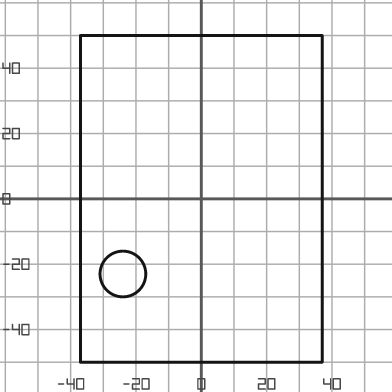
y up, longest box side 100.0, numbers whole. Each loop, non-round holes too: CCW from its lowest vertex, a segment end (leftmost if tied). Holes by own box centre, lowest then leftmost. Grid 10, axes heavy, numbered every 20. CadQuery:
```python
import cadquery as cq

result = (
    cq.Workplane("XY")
    .moveTo(-37.0, -50.0)
    .lineTo(37.0, -50.0)
    .lineTo(37.0, 50.0)
    .lineTo(-37.0, 50.0)
    .close()
    .moveTo(-24.0, -23.0)
    .circle(7.0)
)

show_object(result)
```